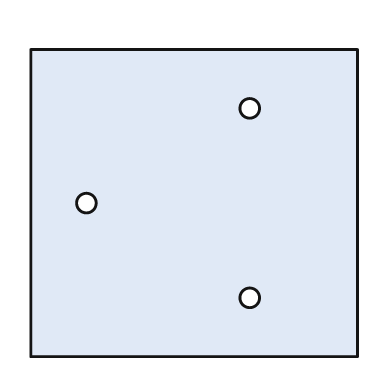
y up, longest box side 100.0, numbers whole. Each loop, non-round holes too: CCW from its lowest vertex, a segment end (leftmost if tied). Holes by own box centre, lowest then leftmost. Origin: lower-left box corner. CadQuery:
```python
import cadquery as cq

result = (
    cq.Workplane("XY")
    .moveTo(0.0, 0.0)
    .lineTo(100.0, 0.0)
    .lineTo(100.0, 94.0)
    .lineTo(0.0, 94.0)
    .close()
    .moveTo(67.0, 18.0)
    .circle(3.0)
    .moveTo(17.0, 47.0)
    .circle(3.0)
    .moveTo(67.0, 76.0)
    .circle(3.0)
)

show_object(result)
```